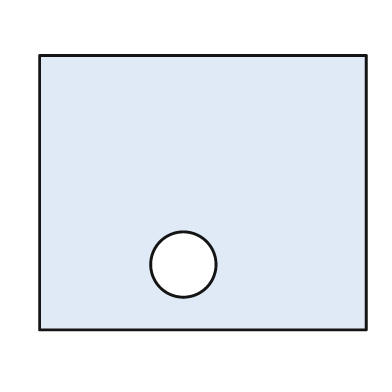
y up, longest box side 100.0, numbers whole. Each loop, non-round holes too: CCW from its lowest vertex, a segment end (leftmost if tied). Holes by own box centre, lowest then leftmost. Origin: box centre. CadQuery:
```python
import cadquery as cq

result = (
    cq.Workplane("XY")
    .moveTo(-50.0, -42.0)
    .lineTo(50.0, -42.0)
    .lineTo(50.0, 42.0)
    .lineTo(-50.0, 42.0)
    .close()
    .moveTo(-6.0, -22.0)
    .circle(10.0)
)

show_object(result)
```